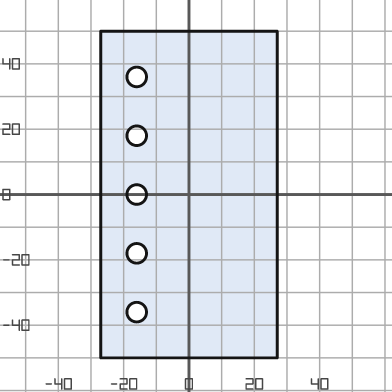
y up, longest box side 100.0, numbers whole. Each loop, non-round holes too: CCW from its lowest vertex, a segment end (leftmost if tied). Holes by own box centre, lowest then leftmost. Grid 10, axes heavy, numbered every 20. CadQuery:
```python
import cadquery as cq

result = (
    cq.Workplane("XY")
    .moveTo(-27.0, -50.0)
    .lineTo(27.0, -50.0)
    .lineTo(27.0, 50.0)
    .lineTo(-27.0, 50.0)
    .close()
    .moveTo(-16.0, -36.0)
    .circle(3.0)
    .moveTo(-16.0, -18.0)
    .circle(3.0)
    .moveTo(-16.0, 0.0)
    .circle(3.0)
    .moveTo(-16.0, 18.0)
    .circle(3.0)
    .moveTo(-16.0, 36.0)
    .circle(3.0)
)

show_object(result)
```